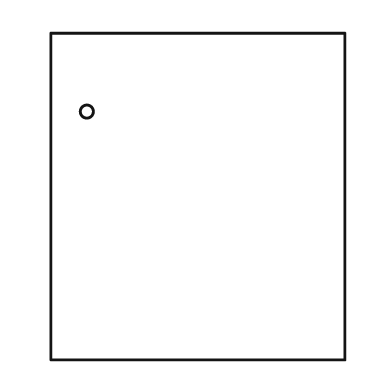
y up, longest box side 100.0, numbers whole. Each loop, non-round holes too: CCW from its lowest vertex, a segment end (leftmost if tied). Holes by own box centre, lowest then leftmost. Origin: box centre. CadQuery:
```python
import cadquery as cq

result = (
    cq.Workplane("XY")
    .moveTo(-45.0, -50.0)
    .lineTo(45.0, -50.0)
    .lineTo(45.0, 50.0)
    .lineTo(-45.0, 50.0)
    .close()
    .moveTo(-34.0, 26.0)
    .circle(2.0)
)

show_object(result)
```